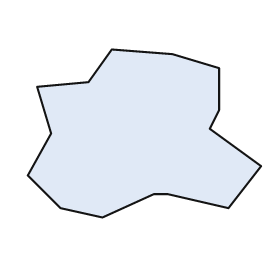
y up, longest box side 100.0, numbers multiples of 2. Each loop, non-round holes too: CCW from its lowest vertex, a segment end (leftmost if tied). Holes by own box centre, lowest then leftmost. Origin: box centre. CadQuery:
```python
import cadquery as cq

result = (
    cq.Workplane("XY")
    .moveTo(-18.0, -36.0)
    .lineTo(4.0, -26.0)
    .lineTo(10.0, -26.0)
    .lineTo(36.0, -32.0)
    .lineTo(50.0, -14.0)
    .lineTo(28.0, 2.0)
    .lineTo(32.0, 10.0)
    .lineTo(32.0, 28.0)
    .lineTo(12.0, 34.0)
    .lineTo(-14.0, 36.0)
    .lineTo(-24.0, 22.0)
    .lineTo(-46.0, 20.0)
    .lineTo(-40.0, 0.0)
    .lineTo(-50.0, -18.0)
    .lineTo(-36.0, -32.0)
    .close()
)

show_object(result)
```